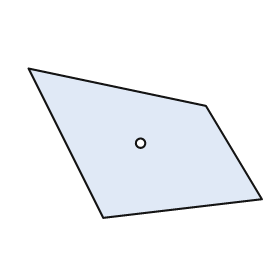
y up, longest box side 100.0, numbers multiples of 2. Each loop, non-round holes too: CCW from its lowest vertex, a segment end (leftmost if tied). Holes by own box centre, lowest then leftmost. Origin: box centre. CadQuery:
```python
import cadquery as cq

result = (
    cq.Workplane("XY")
    .moveTo(-18.0, -32.0)
    .lineTo(50.0, -24.0)
    .lineTo(26.0, 16.0)
    .lineTo(-50.0, 32.0)
    .close()
    .moveTo(-2.0, 0.0)
    .circle(2.0)
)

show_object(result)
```